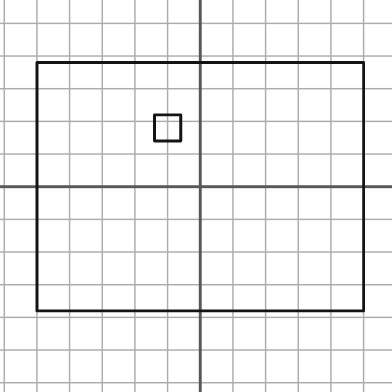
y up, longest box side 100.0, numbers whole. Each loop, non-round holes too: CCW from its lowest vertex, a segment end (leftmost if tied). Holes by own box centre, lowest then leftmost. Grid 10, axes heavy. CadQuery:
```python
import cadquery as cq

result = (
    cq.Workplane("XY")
    .moveTo(-50.0, -38.0)
    .lineTo(50.0, -38.0)
    .lineTo(50.0, 38.0)
    .lineTo(-50.0, 38.0)
    .close()
    .moveTo(-14.0, 14.0)
    .lineTo(-6.0, 14.0)
    .lineTo(-6.0, 22.0)
    .lineTo(-14.0, 22.0)
    .close()
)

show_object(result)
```